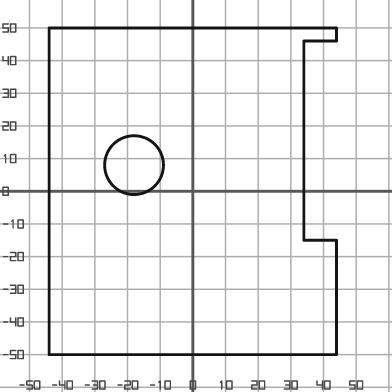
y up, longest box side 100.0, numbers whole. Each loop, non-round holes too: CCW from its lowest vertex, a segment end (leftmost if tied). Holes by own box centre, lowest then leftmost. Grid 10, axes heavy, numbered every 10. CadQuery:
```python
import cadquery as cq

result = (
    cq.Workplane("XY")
    .moveTo(-44.0, -50.0)
    .lineTo(44.0, -50.0)
    .lineTo(44.0, -15.0)
    .lineTo(34.0, -15.0)
    .lineTo(34.0, 46.0)
    .lineTo(44.0, 46.0)
    .lineTo(44.0, 50.0)
    .lineTo(-44.0, 50.0)
    .close()
    .moveTo(-18.0, 8.0)
    .circle(9.0)
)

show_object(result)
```